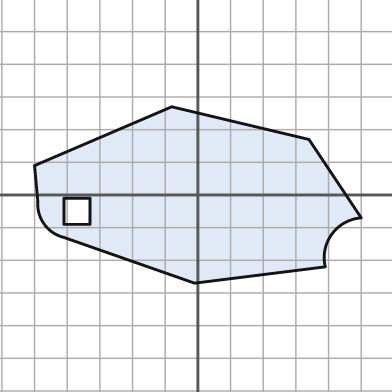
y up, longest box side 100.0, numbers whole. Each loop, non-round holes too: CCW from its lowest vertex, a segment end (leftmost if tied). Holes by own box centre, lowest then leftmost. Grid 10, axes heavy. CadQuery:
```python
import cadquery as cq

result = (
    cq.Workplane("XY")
    .moveTo(-1.0, -27.0)
    .lineTo(39.0, -22.0)
    .threePointArc((41.0, -12.0), (50.0, -7.0))
    .lineTo(34.0, 17.0)
    .lineTo(-8.0, 27.0)
    .lineTo(-50.0, 9.0)
    .lineTo(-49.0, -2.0)
    .threePointArc((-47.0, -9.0), (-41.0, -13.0))
    .close()
    .moveTo(-41.0, -9.0)
    .lineTo(-33.0, -9.0)
    .lineTo(-33.0, -1.0)
    .lineTo(-41.0, -1.0)
    .close()
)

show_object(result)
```